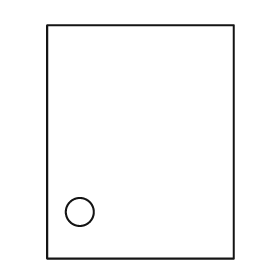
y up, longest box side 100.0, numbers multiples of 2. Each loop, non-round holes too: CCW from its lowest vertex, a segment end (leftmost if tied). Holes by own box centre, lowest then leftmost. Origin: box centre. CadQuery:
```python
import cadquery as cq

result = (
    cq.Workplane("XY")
    .moveTo(-40.0, -50.0)
    .lineTo(40.0, -50.0)
    .lineTo(40.0, 50.0)
    .lineTo(-40.0, 50.0)
    .close()
    .moveTo(-26.0, -30.0)
    .circle(6.0)
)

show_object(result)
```